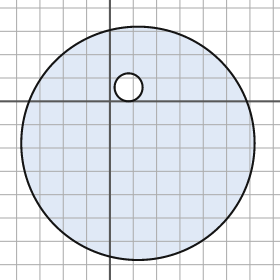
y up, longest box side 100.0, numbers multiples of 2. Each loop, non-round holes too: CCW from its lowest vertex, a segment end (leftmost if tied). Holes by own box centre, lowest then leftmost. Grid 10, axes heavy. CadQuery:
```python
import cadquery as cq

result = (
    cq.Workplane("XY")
    .moveTo(12.0, -18.0)
    .circle(50.0)
    .moveTo(8.0, 6.0)
    .circle(6.0)
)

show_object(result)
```